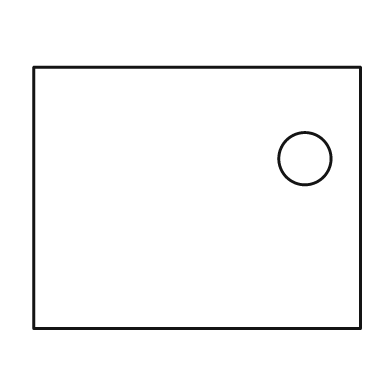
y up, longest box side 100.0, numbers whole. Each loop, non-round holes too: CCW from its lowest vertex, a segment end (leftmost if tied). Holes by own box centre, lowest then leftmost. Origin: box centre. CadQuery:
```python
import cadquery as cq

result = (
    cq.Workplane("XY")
    .moveTo(-50.0, -40.0)
    .lineTo(50.0, -40.0)
    .lineTo(50.0, 40.0)
    .lineTo(-50.0, 40.0)
    .close()
    .moveTo(33.0, 12.0)
    .circle(8.0)
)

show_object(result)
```